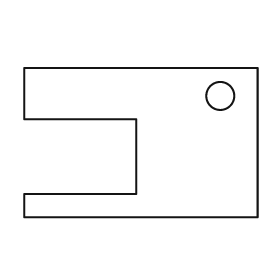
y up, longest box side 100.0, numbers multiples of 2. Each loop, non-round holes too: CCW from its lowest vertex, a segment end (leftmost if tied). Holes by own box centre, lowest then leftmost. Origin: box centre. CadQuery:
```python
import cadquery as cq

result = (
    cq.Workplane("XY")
    .moveTo(-50.0, -32.0)
    .lineTo(50.0, -32.0)
    .lineTo(50.0, 32.0)
    .lineTo(-50.0, 32.0)
    .lineTo(-50.0, 10.0)
    .lineTo(-2.0, 10.0)
    .lineTo(-2.0, -22.0)
    .lineTo(-50.0, -22.0)
    .close()
    .moveTo(34.0, 20.0)
    .circle(6.0)
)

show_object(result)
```